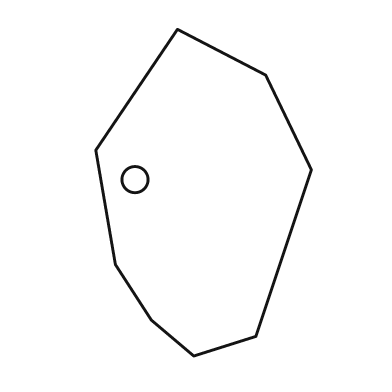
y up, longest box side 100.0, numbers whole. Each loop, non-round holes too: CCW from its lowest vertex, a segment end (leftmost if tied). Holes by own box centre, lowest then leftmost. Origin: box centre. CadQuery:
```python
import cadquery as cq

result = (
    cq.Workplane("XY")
    .moveTo(-3.0, -50.0)
    .lineTo(16.0, -44.0)
    .lineTo(33.0, 7.0)
    .lineTo(19.0, 36.0)
    .lineTo(-8.0, 50.0)
    .lineTo(-33.0, 13.0)
    .lineTo(-27.0, -22.0)
    .lineTo(-16.0, -39.0)
    .close()
    .moveTo(-21.0, 4.0)
    .circle(4.0)
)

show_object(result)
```